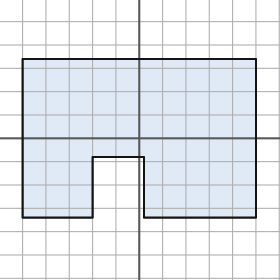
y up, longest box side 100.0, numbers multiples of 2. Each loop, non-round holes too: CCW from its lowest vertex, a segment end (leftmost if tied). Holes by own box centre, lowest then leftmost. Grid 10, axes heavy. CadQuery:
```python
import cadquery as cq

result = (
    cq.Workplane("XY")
    .moveTo(-50.0, -34.0)
    .lineTo(-20.0, -34.0)
    .lineTo(-20.0, -8.0)
    .lineTo(2.0, -8.0)
    .lineTo(2.0, -34.0)
    .lineTo(50.0, -34.0)
    .lineTo(50.0, 34.0)
    .lineTo(-50.0, 34.0)
    .close()
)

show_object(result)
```